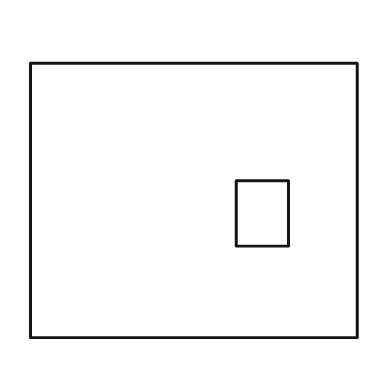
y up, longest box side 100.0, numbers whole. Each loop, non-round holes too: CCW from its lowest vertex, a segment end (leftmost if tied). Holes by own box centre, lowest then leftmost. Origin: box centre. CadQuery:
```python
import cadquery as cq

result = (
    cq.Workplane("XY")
    .moveTo(-50.0, -42.0)
    .lineTo(50.0, -42.0)
    .lineTo(50.0, 42.0)
    .lineTo(-50.0, 42.0)
    .close()
    .moveTo(13.0, -14.0)
    .lineTo(29.0, -14.0)
    .lineTo(29.0, 6.0)
    .lineTo(13.0, 6.0)
    .close()
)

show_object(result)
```